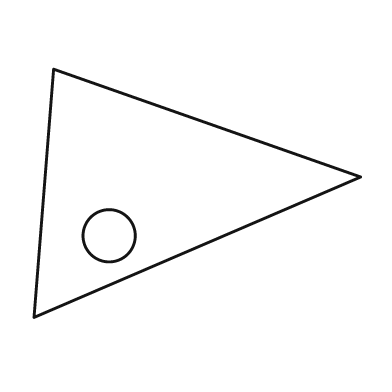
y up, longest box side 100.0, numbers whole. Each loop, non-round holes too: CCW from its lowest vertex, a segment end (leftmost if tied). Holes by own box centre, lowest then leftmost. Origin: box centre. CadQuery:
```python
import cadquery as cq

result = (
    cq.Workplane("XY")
    .moveTo(-50.0, -38.0)
    .lineTo(50.0, 5.0)
    .lineTo(-44.0, 38.0)
    .close()
    .moveTo(-27.0, -13.0)
    .circle(8.0)
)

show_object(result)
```